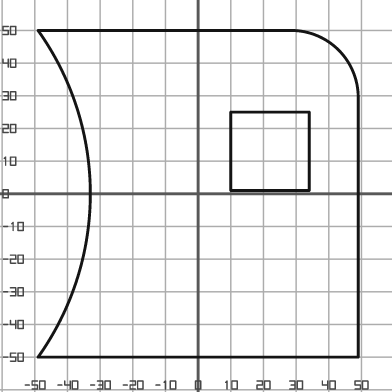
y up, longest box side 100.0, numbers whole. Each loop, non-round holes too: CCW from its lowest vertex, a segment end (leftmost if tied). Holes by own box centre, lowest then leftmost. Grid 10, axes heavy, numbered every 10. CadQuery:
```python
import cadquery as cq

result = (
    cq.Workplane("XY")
    .moveTo(-49.0, -50.0)
    .lineTo(49.0, -50.0)
    .lineTo(49.0, 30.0)
    .threePointArc((43.0, 44.0), (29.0, 50.0))
    .lineTo(-49.0, 50.0)
    .threePointArc((-33.0, 0.0), (-49.0, -50.0))
    .close()
    .moveTo(10.0, 1.0)
    .lineTo(34.0, 1.0)
    .lineTo(34.0, 25.0)
    .lineTo(10.0, 25.0)
    .close()
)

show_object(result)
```